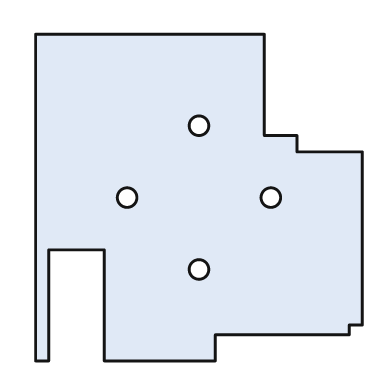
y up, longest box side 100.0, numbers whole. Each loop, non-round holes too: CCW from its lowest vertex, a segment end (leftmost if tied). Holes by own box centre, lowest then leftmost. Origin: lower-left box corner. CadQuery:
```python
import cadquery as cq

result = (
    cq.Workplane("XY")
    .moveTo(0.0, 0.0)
    .lineTo(4.0, 0.0)
    .lineTo(4.0, 34.0)
    .lineTo(21.0, 34.0)
    .lineTo(21.0, 0.0)
    .lineTo(55.0, 0.0)
    .lineTo(55.0, 8.0)
    .lineTo(96.0, 8.0)
    .lineTo(96.0, 11.0)
    .lineTo(100.0, 11.0)
    .lineTo(100.0, 64.0)
    .lineTo(80.0, 64.0)
    .lineTo(80.0, 69.0)
    .lineTo(70.0, 69.0)
    .lineTo(70.0, 100.0)
    .lineTo(0.0, 100.0)
    .close()
    .moveTo(50.0, 28.0)
    .circle(3.0)
    .moveTo(28.0, 50.0)
    .circle(3.0)
    .moveTo(72.0, 50.0)
    .circle(3.0)
    .moveTo(50.0, 72.0)
    .circle(3.0)
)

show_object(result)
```